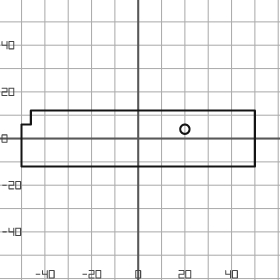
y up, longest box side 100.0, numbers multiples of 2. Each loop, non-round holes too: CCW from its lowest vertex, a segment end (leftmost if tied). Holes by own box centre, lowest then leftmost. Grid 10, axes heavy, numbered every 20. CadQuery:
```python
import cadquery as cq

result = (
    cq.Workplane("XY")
    .moveTo(-50.0, -12.0)
    .lineTo(50.0, -12.0)
    .lineTo(50.0, 12.0)
    .lineTo(-46.0, 12.0)
    .lineTo(-46.0, 6.0)
    .lineTo(-50.0, 6.0)
    .close()
    .moveTo(20.0, 4.0)
    .circle(2.0)
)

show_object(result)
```